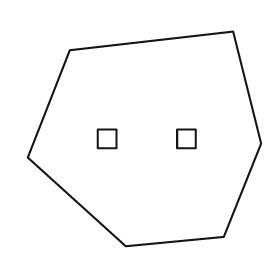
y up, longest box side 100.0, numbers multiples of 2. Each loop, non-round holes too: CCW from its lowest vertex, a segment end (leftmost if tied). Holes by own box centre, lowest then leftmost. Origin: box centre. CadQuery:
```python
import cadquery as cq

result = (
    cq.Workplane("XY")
    .moveTo(-8.0, -46.0)
    .lineTo(34.0, -42.0)
    .lineTo(50.0, -2.0)
    .lineTo(38.0, 46.0)
    .lineTo(-32.0, 38.0)
    .lineTo(-50.0, -8.0)
    .close()
    .moveTo(-20.0, -4.0)
    .lineTo(-12.0, -4.0)
    .lineTo(-12.0, 4.0)
    .lineTo(-20.0, 4.0)
    .close()
    .moveTo(14.0, -4.0)
    .lineTo(22.0, -4.0)
    .lineTo(22.0, 4.0)
    .lineTo(14.0, 4.0)
    .close()
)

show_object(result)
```